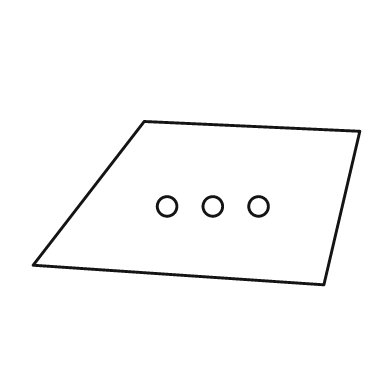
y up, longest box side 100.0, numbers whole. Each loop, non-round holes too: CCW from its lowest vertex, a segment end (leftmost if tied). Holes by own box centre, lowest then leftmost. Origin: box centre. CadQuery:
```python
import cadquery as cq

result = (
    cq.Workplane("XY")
    .moveTo(39.0, -25.0)
    .lineTo(50.0, 22.0)
    .lineTo(-16.0, 25.0)
    .lineTo(-50.0, -19.0)
    .close()
    .moveTo(-9.0, -1.0)
    .circle(3.0)
    .moveTo(5.0, -1.0)
    .circle(3.0)
    .moveTo(19.0, -1.0)
    .circle(3.0)
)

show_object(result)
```